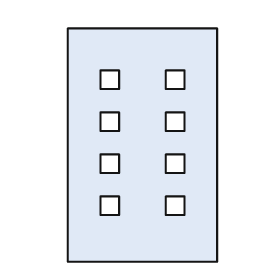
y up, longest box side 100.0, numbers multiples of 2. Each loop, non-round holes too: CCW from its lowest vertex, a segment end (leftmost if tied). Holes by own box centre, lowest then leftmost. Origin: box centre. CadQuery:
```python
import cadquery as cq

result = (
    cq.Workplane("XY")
    .moveTo(-32.0, -50.0)
    .lineTo(32.0, -50.0)
    .lineTo(32.0, 50.0)
    .lineTo(-32.0, 50.0)
    .close()
    .moveTo(-18.0, -30.0)
    .lineTo(-10.0, -30.0)
    .lineTo(-10.0, -22.0)
    .lineTo(-18.0, -22.0)
    .close()
    .moveTo(10.0, -30.0)
    .lineTo(18.0, -30.0)
    .lineTo(18.0, -22.0)
    .lineTo(10.0, -22.0)
    .close()
    .moveTo(-18.0, -12.0)
    .lineTo(-10.0, -12.0)
    .lineTo(-10.0, -4.0)
    .lineTo(-18.0, -4.0)
    .close()
    .moveTo(10.0, -12.0)
    .lineTo(18.0, -12.0)
    .lineTo(18.0, -4.0)
    .lineTo(10.0, -4.0)
    .close()
    .moveTo(-18.0, 6.0)
    .lineTo(-10.0, 6.0)
    .lineTo(-10.0, 14.0)
    .lineTo(-18.0, 14.0)
    .close()
    .moveTo(10.0, 6.0)
    .lineTo(18.0, 6.0)
    .lineTo(18.0, 14.0)
    .lineTo(10.0, 14.0)
    .close()
    .moveTo(-18.0, 24.0)
    .lineTo(-10.0, 24.0)
    .lineTo(-10.0, 32.0)
    .lineTo(-18.0, 32.0)
    .close()
    .moveTo(10.0, 24.0)
    .lineTo(18.0, 24.0)
    .lineTo(18.0, 32.0)
    .lineTo(10.0, 32.0)
    .close()
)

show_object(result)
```